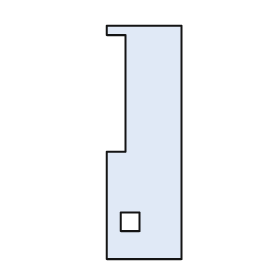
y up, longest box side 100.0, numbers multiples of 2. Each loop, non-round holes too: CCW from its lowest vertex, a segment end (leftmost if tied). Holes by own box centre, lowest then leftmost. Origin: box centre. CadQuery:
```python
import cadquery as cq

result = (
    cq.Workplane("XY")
    .moveTo(-16.0, -50.0)
    .lineTo(16.0, -50.0)
    .lineTo(16.0, 50.0)
    .lineTo(-16.0, 50.0)
    .lineTo(-16.0, 46.0)
    .lineTo(-8.0, 46.0)
    .lineTo(-8.0, -4.0)
    .lineTo(-16.0, -4.0)
    .close()
    .moveTo(-10.0, -38.0)
    .lineTo(-2.0, -38.0)
    .lineTo(-2.0, -30.0)
    .lineTo(-10.0, -30.0)
    .close()
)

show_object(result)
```